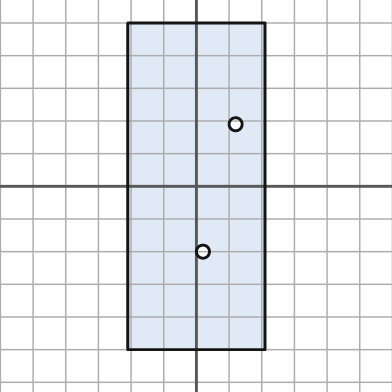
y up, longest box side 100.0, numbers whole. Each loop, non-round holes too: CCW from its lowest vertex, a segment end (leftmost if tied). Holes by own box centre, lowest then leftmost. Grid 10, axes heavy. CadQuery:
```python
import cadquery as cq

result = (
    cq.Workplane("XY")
    .moveTo(-21.0, -50.0)
    .lineTo(21.0, -50.0)
    .lineTo(21.0, 50.0)
    .lineTo(-21.0, 50.0)
    .close()
    .moveTo(2.0, -20.0)
    .circle(2.0)
    .moveTo(12.0, 19.0)
    .circle(2.0)
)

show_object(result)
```